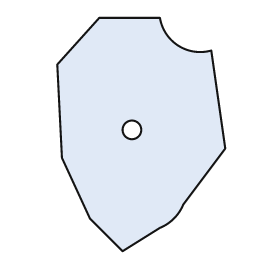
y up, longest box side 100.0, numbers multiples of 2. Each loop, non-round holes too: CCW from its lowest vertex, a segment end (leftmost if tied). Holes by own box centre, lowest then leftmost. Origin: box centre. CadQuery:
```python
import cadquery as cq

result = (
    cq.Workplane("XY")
    .moveTo(-8.0, -50.0)
    .lineTo(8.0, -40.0)
    .threePointArc((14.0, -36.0), (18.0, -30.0))
    .lineTo(36.0, -6.0)
    .lineTo(30.0, 36.0)
    .threePointArc((16.0, 38.0), (8.0, 50.0))
    .lineTo(-18.0, 50.0)
    .lineTo(-36.0, 30.0)
    .lineTo(-34.0, -10.0)
    .lineTo(-22.0, -36.0)
    .close()
    .moveTo(-4.0, 2.0)
    .circle(4.0)
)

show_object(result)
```